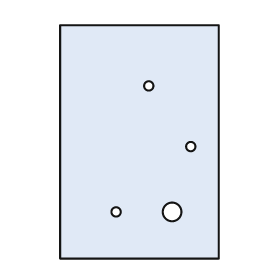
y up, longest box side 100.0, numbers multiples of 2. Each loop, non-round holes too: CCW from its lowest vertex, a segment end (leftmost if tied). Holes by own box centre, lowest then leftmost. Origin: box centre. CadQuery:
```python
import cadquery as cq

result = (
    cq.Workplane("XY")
    .moveTo(-34.0, -50.0)
    .lineTo(34.0, -50.0)
    .lineTo(34.0, 50.0)
    .lineTo(-34.0, 50.0)
    .close()
    .moveTo(-10.0, -30.0)
    .circle(2.0)
    .moveTo(14.0, -30.0)
    .circle(4.0)
    .moveTo(22.0, -2.0)
    .circle(2.0)
    .moveTo(4.0, 24.0)
    .circle(2.0)
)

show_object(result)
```